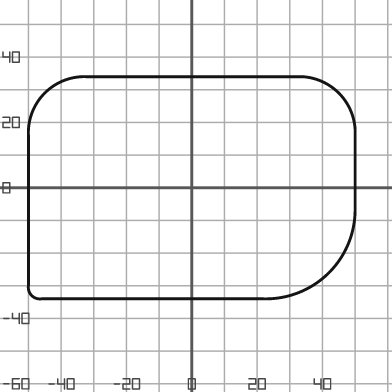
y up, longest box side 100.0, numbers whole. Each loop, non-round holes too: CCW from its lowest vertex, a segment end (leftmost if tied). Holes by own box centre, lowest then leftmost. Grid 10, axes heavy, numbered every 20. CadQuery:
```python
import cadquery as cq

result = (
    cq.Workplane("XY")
    .moveTo(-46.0, -34.0)
    .lineTo(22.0, -34.0)
    .threePointArc((42.0, -26.0), (50.0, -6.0))
    .lineTo(50.0, 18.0)
    .threePointArc((45.0, 29.0), (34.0, 34.0))
    .lineTo(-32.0, 34.0)
    .threePointArc((-45.0, 29.0), (-50.0, 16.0))
    .lineTo(-50.0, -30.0)
    .threePointArc((-49.0, -33.0), (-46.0, -34.0))
    .close()
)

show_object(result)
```